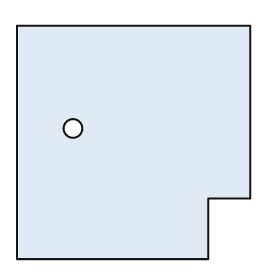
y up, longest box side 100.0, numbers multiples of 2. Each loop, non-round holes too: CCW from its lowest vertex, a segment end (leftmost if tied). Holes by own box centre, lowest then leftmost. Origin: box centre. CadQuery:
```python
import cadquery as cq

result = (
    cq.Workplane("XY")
    .moveTo(-50.0, -50.0)
    .lineTo(32.0, -50.0)
    .lineTo(32.0, -24.0)
    .lineTo(50.0, -24.0)
    .lineTo(50.0, 50.0)
    .lineTo(-50.0, 50.0)
    .close()
    .moveTo(-26.0, 6.0)
    .circle(4.0)
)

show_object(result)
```